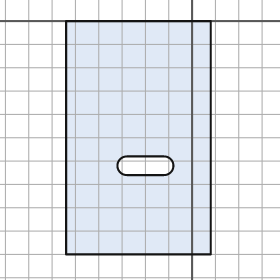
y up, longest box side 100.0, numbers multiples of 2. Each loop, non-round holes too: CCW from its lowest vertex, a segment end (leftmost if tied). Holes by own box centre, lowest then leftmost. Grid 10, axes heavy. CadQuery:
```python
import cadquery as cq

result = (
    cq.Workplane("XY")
    .moveTo(-54.0, -100.0)
    .lineTo(8.0, -100.0)
    .lineTo(8.0, 0.0)
    .lineTo(-54.0, 0.0)
    .close()
    .moveTo(-28.0, -66.0)
    .lineTo(-12.0, -66.0)
    .threePointArc((-8.0, -62.0), (-12.0, -58.0))
    .lineTo(-28.0, -58.0)
    .threePointArc((-32.0, -62.0), (-28.0, -66.0))
    .close()
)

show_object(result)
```